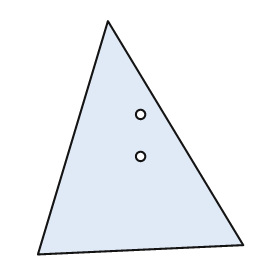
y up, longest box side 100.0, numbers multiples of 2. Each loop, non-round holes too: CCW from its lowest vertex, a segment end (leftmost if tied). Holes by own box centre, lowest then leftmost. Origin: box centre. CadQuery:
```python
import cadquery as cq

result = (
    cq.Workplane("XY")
    .moveTo(-44.0, -50.0)
    .lineTo(44.0, -46.0)
    .lineTo(-14.0, 50.0)
    .close()
    .moveTo(0.0, -8.0)
    .circle(2.0)
    .moveTo(0.0, 10.0)
    .circle(2.0)
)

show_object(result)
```